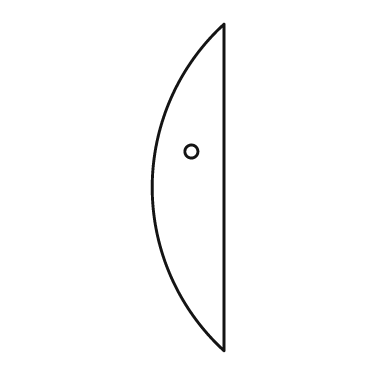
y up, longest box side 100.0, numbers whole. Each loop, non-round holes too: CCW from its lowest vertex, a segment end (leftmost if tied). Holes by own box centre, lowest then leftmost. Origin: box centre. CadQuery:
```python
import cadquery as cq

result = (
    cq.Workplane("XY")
    .moveTo(11.0, -50.0)
    .lineTo(11.0, 50.0)
    .threePointArc((-11.0, 0.0), (11.0, -50.0))
    .close()
    .moveTo(1.0, 11.0)
    .circle(2.0)
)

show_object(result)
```